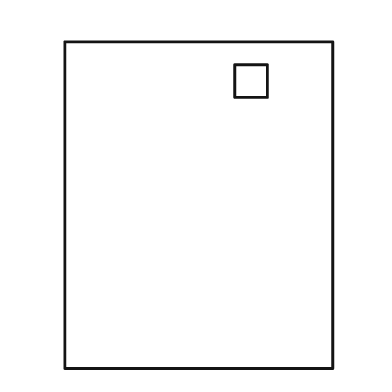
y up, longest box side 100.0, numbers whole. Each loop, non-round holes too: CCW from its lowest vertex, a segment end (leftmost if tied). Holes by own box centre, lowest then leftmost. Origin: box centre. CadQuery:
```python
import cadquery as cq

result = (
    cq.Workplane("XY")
    .moveTo(-41.0, -50.0)
    .lineTo(41.0, -50.0)
    .lineTo(41.0, 50.0)
    .lineTo(-41.0, 50.0)
    .close()
    .moveTo(11.0, 33.0)
    .lineTo(21.0, 33.0)
    .lineTo(21.0, 43.0)
    .lineTo(11.0, 43.0)
    .close()
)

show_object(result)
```